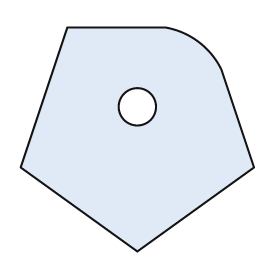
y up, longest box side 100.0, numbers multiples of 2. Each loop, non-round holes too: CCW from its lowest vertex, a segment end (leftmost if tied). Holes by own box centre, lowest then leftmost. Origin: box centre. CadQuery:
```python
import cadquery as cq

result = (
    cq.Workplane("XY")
    .moveTo(0.0, -48.0)
    .lineTo(50.0, -12.0)
    .lineTo(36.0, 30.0)
    .threePointArc((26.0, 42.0), (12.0, 48.0))
    .lineTo(-30.0, 48.0)
    .lineTo(-50.0, -12.0)
    .close()
    .moveTo(0.0, 14.0)
    .circle(8.0)
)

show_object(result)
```